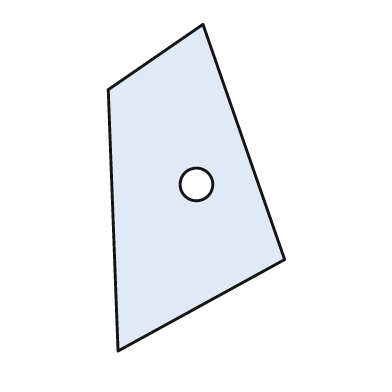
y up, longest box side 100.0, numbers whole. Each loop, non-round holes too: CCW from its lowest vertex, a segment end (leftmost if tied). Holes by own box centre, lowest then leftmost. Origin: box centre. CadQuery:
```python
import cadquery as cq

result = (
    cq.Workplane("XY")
    .moveTo(-24.0, -50.0)
    .lineTo(27.0, -22.0)
    .lineTo(2.0, 50.0)
    .lineTo(-27.0, 30.0)
    .close()
    .moveTo(0.0, 1.0)
    .circle(5.0)
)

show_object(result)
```